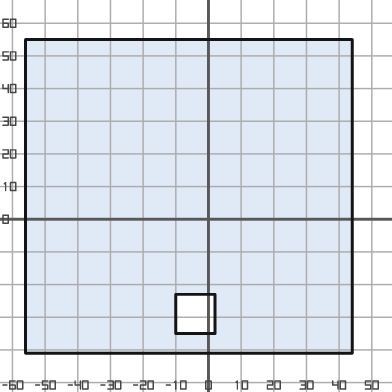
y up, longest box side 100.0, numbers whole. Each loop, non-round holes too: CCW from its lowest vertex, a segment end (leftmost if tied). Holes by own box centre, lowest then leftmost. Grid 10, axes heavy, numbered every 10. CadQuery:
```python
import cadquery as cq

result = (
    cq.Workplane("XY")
    .moveTo(-56.0, -41.0)
    .lineTo(44.0, -41.0)
    .lineTo(44.0, 55.0)
    .lineTo(-56.0, 55.0)
    .close()
    .moveTo(-10.0, -35.0)
    .lineTo(2.0, -35.0)
    .lineTo(2.0, -23.0)
    .lineTo(-10.0, -23.0)
    .close()
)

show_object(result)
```